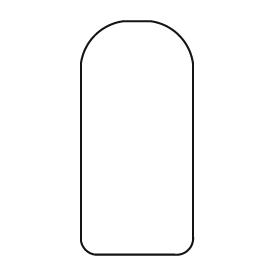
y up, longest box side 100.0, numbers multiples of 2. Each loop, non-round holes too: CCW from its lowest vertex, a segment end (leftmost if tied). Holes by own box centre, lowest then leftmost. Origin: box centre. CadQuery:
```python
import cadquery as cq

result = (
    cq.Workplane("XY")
    .moveTo(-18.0, -50.0)
    .lineTo(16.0, -50.0)
    .threePointArc((22.0, -48.0), (24.0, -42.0))
    .lineTo(24.0, 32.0)
    .threePointArc((18.0, 44.0), (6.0, 50.0))
    .lineTo(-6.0, 50.0)
    .threePointArc((-18.0, 44.0), (-24.0, 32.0))
    .lineTo(-24.0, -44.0)
    .threePointArc((-22.0, -48.0), (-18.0, -50.0))
    .close()
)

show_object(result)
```